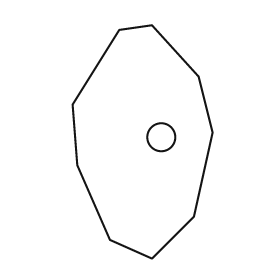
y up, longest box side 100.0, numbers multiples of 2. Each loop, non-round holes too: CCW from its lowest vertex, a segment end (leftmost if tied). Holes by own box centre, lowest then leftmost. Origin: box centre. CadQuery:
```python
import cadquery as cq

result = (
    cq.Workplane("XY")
    .moveTo(4.0, -50.0)
    .lineTo(22.0, -32.0)
    .lineTo(30.0, 4.0)
    .lineTo(24.0, 28.0)
    .lineTo(4.0, 50.0)
    .lineTo(-10.0, 48.0)
    .lineTo(-30.0, 16.0)
    .lineTo(-28.0, -10.0)
    .lineTo(-14.0, -42.0)
    .close()
    .moveTo(8.0, 2.0)
    .circle(6.0)
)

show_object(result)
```